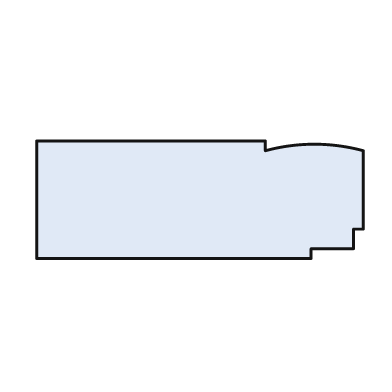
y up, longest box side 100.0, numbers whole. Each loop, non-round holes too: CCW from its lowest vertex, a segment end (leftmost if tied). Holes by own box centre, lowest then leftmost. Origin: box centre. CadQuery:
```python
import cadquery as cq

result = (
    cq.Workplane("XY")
    .moveTo(-50.0, -18.0)
    .lineTo(34.0, -18.0)
    .lineTo(34.0, -15.0)
    .lineTo(47.0, -15.0)
    .lineTo(47.0, -9.0)
    .lineTo(50.0, -9.0)
    .lineTo(50.0, 15.0)
    .threePointArc((35.0, 17.0), (20.0, 15.0))
    .lineTo(20.0, 18.0)
    .lineTo(-50.0, 18.0)
    .close()
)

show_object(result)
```